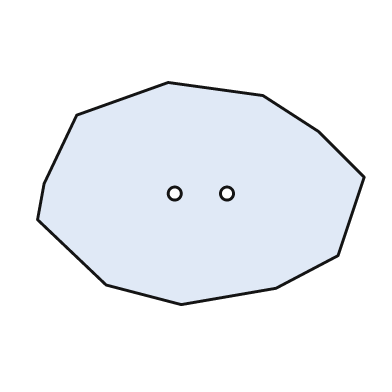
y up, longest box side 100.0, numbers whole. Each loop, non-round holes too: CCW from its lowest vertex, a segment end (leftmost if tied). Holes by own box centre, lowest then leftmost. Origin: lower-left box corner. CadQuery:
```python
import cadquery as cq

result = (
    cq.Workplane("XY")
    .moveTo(44.0, 0.0)
    .lineTo(73.0, 5.0)
    .lineTo(92.0, 15.0)
    .lineTo(100.0, 39.0)
    .lineTo(86.0, 53.0)
    .lineTo(69.0, 64.0)
    .lineTo(40.0, 68.0)
    .lineTo(12.0, 58.0)
    .lineTo(2.0, 37.0)
    .lineTo(0.0, 26.0)
    .lineTo(21.0, 6.0)
    .close()
    .moveTo(42.0, 34.0)
    .circle(2.0)
    .moveTo(58.0, 34.0)
    .circle(2.0)
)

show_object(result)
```